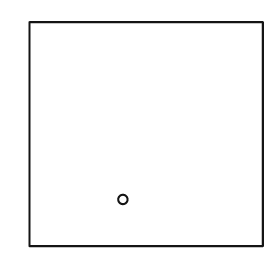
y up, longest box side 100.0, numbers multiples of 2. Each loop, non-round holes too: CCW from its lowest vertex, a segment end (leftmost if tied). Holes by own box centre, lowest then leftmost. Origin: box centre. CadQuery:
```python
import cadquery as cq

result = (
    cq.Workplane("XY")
    .moveTo(-50.0, -48.0)
    .lineTo(50.0, -48.0)
    .lineTo(50.0, 48.0)
    .lineTo(-50.0, 48.0)
    .close()
    .moveTo(-10.0, -28.0)
    .circle(2.0)
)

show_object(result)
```